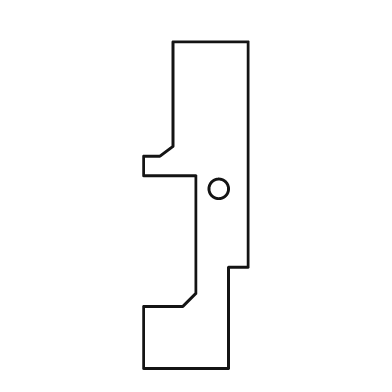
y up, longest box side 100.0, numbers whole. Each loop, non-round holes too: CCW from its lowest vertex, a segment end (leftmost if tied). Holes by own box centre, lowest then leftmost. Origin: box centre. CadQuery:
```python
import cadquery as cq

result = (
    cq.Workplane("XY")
    .moveTo(-16.0, -50.0)
    .lineTo(10.0, -50.0)
    .lineTo(10.0, -19.0)
    .lineTo(16.0, -19.0)
    .lineTo(16.0, 50.0)
    .lineTo(-7.0, 50.0)
    .lineTo(-7.0, 18.0)
    .lineTo(-11.0, 15.0)
    .lineTo(-16.0, 15.0)
    .lineTo(-16.0, 9.0)
    .lineTo(0.0, 9.0)
    .lineTo(0.0, -27.0)
    .lineTo(-4.0, -31.0)
    .lineTo(-16.0, -31.0)
    .close()
    .moveTo(7.0, 5.0)
    .circle(3.0)
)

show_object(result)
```